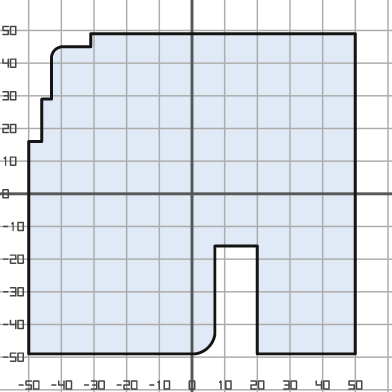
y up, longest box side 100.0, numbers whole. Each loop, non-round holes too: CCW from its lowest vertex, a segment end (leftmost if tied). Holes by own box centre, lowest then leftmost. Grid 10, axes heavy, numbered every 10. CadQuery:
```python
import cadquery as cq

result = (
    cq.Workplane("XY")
    .moveTo(-50.0, -49.0)
    .lineTo(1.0, -49.0)
    .threePointArc((5.0, -47.0), (7.0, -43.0))
    .lineTo(7.0, -16.0)
    .lineTo(20.0, -16.0)
    .lineTo(20.0, -49.0)
    .lineTo(50.0, -49.0)
    .lineTo(50.0, 49.0)
    .lineTo(-31.0, 49.0)
    .lineTo(-31.0, 45.0)
    .lineTo(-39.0, 45.0)
    .threePointArc((-42.0, 44.0), (-43.0, 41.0))
    .lineTo(-43.0, 29.0)
    .lineTo(-46.0, 29.0)
    .lineTo(-46.0, 16.0)
    .lineTo(-50.0, 16.0)
    .close()
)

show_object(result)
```